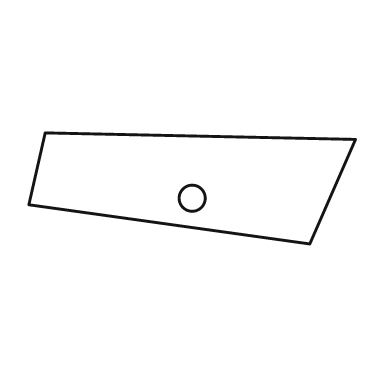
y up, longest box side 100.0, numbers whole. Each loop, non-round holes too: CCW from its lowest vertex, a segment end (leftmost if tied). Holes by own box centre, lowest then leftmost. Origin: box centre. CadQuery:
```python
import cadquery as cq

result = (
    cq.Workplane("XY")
    .moveTo(36.0, -17.0)
    .lineTo(50.0, 15.0)
    .lineTo(-45.0, 17.0)
    .lineTo(-50.0, -5.0)
    .close()
    .moveTo(0.0, -3.0)
    .circle(4.0)
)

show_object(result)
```